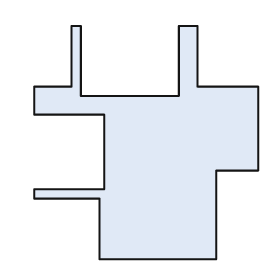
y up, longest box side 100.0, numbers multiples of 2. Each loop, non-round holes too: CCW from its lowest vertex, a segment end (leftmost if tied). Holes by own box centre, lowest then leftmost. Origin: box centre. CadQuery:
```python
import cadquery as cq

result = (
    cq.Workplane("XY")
    .moveTo(-20.0, -50.0)
    .lineTo(30.0, -50.0)
    .lineTo(30.0, -12.0)
    .lineTo(48.0, -12.0)
    .lineTo(48.0, 24.0)
    .lineTo(22.0, 24.0)
    .lineTo(22.0, 50.0)
    .lineTo(14.0, 50.0)
    .lineTo(14.0, 20.0)
    .lineTo(-28.0, 20.0)
    .lineTo(-28.0, 50.0)
    .lineTo(-32.0, 50.0)
    .lineTo(-32.0, 24.0)
    .lineTo(-48.0, 24.0)
    .lineTo(-48.0, 12.0)
    .lineTo(-18.0, 12.0)
    .lineTo(-18.0, -20.0)
    .lineTo(-48.0, -20.0)
    .lineTo(-48.0, -24.0)
    .lineTo(-20.0, -24.0)
    .close()
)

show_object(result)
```